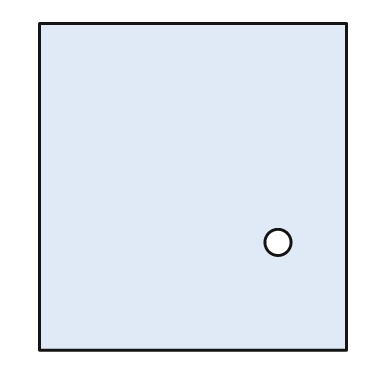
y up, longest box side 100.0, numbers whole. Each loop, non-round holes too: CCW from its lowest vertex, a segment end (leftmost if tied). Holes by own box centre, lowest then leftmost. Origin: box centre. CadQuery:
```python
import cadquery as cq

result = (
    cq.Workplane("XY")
    .moveTo(-47.0, -50.0)
    .lineTo(47.0, -50.0)
    .lineTo(47.0, 50.0)
    .lineTo(-47.0, 50.0)
    .close()
    .moveTo(26.0, -17.0)
    .circle(4.0)
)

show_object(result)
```